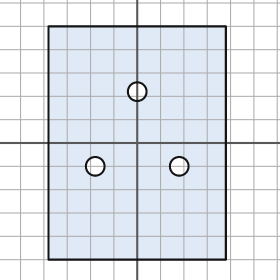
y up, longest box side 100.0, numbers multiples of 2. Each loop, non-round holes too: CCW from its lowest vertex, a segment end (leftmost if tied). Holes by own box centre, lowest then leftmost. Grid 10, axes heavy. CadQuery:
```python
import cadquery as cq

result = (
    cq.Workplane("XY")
    .moveTo(-38.0, -50.0)
    .lineTo(38.0, -50.0)
    .lineTo(38.0, 50.0)
    .lineTo(-38.0, 50.0)
    .close()
    .moveTo(-18.0, -10.0)
    .circle(4.0)
    .moveTo(18.0, -10.0)
    .circle(4.0)
    .moveTo(0.0, 22.0)
    .circle(4.0)
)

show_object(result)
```